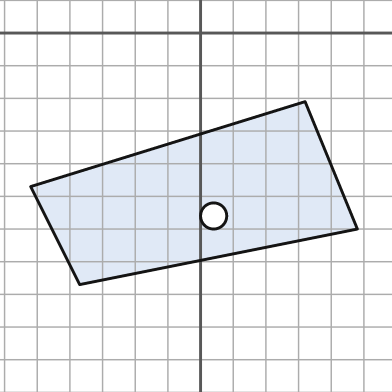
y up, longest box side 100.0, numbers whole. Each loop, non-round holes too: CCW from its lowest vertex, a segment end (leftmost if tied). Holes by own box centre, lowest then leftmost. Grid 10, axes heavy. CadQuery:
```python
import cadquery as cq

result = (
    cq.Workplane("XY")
    .moveTo(-37.0, -77.0)
    .lineTo(48.0, -60.0)
    .lineTo(32.0, -21.0)
    .lineTo(-52.0, -47.0)
    .close()
    .moveTo(4.0, -56.0)
    .circle(4.0)
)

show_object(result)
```